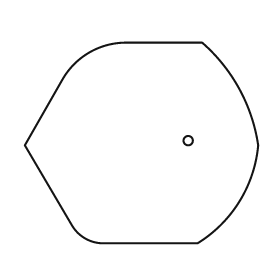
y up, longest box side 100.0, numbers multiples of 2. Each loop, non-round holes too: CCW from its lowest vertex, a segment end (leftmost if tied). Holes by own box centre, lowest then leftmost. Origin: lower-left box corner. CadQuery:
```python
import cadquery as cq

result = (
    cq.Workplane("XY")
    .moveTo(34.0, 0.0)
    .lineTo(74.0, 0.0)
    .threePointArc((92.0, 18.0), (100.0, 42.0))
    .threePointArc((92.0, 66.0), (76.0, 86.0))
    .lineTo(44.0, 86.0)
    .threePointArc((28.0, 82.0), (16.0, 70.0))
    .lineTo(0.0, 42.0)
    .lineTo(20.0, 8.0)
    .threePointArc((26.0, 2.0), (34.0, 0.0))
    .close()
    .moveTo(70.0, 44.0)
    .circle(2.0)
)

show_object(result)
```